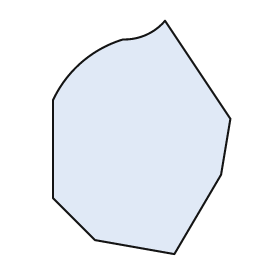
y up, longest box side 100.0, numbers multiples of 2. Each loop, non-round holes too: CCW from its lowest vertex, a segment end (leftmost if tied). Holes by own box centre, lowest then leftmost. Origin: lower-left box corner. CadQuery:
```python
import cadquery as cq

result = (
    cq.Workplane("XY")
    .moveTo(52.0, 0.0)
    .lineTo(72.0, 34.0)
    .lineTo(76.0, 58.0)
    .lineTo(48.0, 100.0)
    .threePointArc((40.0, 94.0), (30.0, 92.0))
    .threePointArc((12.0, 82.0), (0.0, 66.0))
    .lineTo(0.0, 24.0)
    .lineTo(18.0, 6.0)
    .close()
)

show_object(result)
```